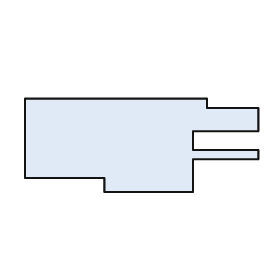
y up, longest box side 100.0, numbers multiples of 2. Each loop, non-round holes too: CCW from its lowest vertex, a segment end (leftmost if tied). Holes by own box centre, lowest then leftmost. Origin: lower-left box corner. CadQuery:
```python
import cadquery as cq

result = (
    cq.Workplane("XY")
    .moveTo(34.0, 0.0)
    .lineTo(72.0, 0.0)
    .lineTo(72.0, 14.0)
    .lineTo(100.0, 14.0)
    .lineTo(100.0, 18.0)
    .lineTo(72.0, 18.0)
    .lineTo(72.0, 26.0)
    .lineTo(100.0, 26.0)
    .lineTo(100.0, 36.0)
    .lineTo(78.0, 36.0)
    .lineTo(78.0, 40.0)
    .lineTo(0.0, 40.0)
    .lineTo(0.0, 6.0)
    .lineTo(34.0, 6.0)
    .close()
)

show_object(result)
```